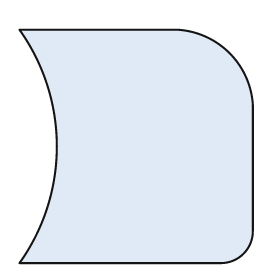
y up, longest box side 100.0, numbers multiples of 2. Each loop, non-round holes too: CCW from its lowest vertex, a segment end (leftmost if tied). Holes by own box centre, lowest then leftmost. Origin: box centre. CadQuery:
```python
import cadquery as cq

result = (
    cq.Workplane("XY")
    .moveTo(-50.0, -50.0)
    .lineTo(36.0, -50.0)
    .threePointArc((46.0, -46.0), (50.0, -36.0))
    .lineTo(50.0, 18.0)
    .threePointArc((40.0, 40.0), (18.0, 50.0))
    .lineTo(-50.0, 50.0)
    .threePointArc((-34.0, 0.0), (-50.0, -50.0))
    .close()
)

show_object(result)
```